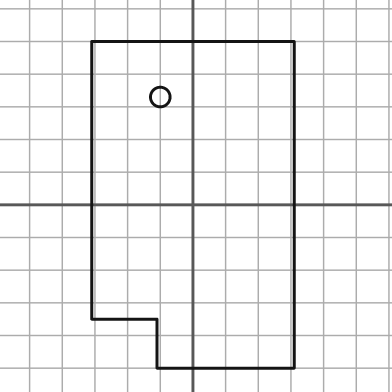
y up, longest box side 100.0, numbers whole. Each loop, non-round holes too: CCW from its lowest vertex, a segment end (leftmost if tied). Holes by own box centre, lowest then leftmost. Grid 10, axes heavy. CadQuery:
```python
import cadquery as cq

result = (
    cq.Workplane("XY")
    .moveTo(-11.0, -50.0)
    .lineTo(31.0, -50.0)
    .lineTo(31.0, 50.0)
    .lineTo(-31.0, 50.0)
    .lineTo(-31.0, -35.0)
    .lineTo(-11.0, -35.0)
    .close()
    .moveTo(-10.0, 33.0)
    .circle(3.0)
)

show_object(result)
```